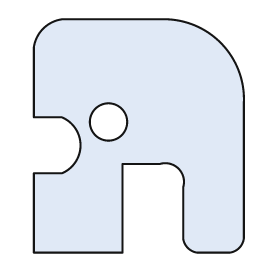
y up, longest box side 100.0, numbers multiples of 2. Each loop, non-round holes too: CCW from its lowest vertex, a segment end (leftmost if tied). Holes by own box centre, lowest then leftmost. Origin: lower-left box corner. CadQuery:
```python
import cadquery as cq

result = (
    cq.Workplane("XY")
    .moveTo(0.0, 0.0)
    .lineTo(38.0, 0.0)
    .lineTo(38.0, 38.0)
    .lineTo(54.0, 38.0)
    .threePointArc((62.0, 36.0), (64.0, 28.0))
    .lineTo(64.0, 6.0)
    .threePointArc((66.0, 2.0), (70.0, 0.0))
    .lineTo(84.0, 0.0)
    .threePointArc((88.0, 2.0), (90.0, 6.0))
    .lineTo(90.0, 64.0)
    .threePointArc((80.0, 90.0), (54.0, 100.0))
    .lineTo(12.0, 100.0)
    .threePointArc((4.0, 96.0), (0.0, 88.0))
    .lineTo(0.0, 58.0)
    .lineTo(12.0, 58.0)
    .threePointArc((20.0, 46.0), (12.0, 34.0))
    .lineTo(0.0, 34.0)
    .close()
    .moveTo(32.0, 56.0)
    .circle(8.0)
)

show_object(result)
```